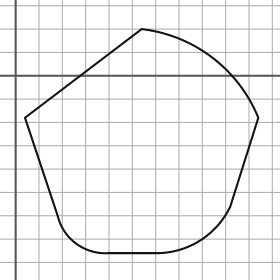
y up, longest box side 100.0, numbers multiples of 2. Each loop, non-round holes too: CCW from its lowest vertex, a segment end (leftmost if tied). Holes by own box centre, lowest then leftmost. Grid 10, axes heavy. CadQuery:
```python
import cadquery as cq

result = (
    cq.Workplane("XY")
    .moveTo(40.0, -76.0)
    .lineTo(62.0, -76.0)
    .threePointArc((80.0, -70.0), (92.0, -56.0))
    .lineTo(104.0, -18.0)
    .threePointArc((84.0, 8.0), (54.0, 20.0))
    .lineTo(4.0, -18.0)
    .lineTo(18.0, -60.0)
    .threePointArc((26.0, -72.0), (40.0, -76.0))
    .close()
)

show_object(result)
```